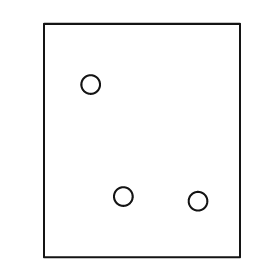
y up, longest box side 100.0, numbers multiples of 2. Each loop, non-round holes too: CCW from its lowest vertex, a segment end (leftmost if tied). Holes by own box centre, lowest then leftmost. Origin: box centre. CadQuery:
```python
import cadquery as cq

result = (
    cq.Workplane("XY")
    .moveTo(-42.0, -50.0)
    .lineTo(42.0, -50.0)
    .lineTo(42.0, 50.0)
    .lineTo(-42.0, 50.0)
    .close()
    .moveTo(24.0, -26.0)
    .circle(4.0)
    .moveTo(-8.0, -24.0)
    .circle(4.0)
    .moveTo(-22.0, 24.0)
    .circle(4.0)
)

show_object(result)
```